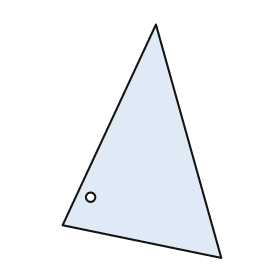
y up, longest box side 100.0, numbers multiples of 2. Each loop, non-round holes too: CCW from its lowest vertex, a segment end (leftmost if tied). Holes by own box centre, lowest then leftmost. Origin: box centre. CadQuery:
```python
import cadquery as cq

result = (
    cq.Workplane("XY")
    .moveTo(34.0, -50.0)
    .lineTo(6.0, 50.0)
    .lineTo(-34.0, -36.0)
    .close()
    .moveTo(-22.0, -24.0)
    .circle(2.0)
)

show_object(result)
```